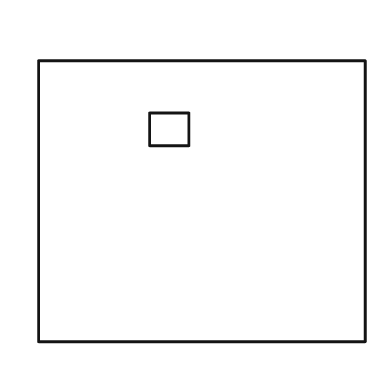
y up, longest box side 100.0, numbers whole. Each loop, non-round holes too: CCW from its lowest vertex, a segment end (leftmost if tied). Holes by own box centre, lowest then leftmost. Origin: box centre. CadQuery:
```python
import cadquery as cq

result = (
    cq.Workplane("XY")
    .moveTo(-50.0, -43.0)
    .lineTo(50.0, -43.0)
    .lineTo(50.0, 43.0)
    .lineTo(-50.0, 43.0)
    .close()
    .moveTo(-16.0, 17.0)
    .lineTo(-4.0, 17.0)
    .lineTo(-4.0, 27.0)
    .lineTo(-16.0, 27.0)
    .close()
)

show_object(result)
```